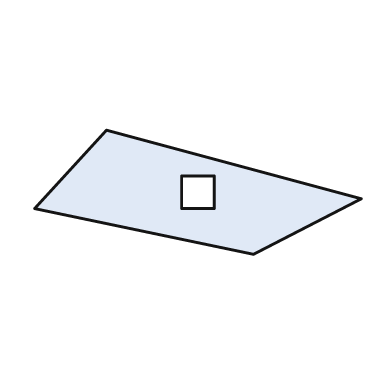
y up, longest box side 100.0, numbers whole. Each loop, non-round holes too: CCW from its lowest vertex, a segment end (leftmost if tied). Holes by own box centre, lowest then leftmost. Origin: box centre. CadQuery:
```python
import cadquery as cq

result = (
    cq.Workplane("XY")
    .moveTo(17.0, -19.0)
    .lineTo(50.0, -2.0)
    .lineTo(-28.0, 19.0)
    .lineTo(-50.0, -5.0)
    .close()
    .moveTo(-5.0, -5.0)
    .lineTo(5.0, -5.0)
    .lineTo(5.0, 5.0)
    .lineTo(-5.0, 5.0)
    .close()
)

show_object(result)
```